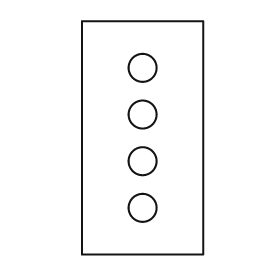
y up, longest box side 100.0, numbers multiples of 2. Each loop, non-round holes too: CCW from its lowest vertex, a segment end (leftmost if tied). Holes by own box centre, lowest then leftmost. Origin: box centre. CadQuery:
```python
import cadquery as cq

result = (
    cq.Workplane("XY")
    .moveTo(-26.0, -50.0)
    .lineTo(26.0, -50.0)
    .lineTo(26.0, 50.0)
    .lineTo(-26.0, 50.0)
    .close()
    .moveTo(0.0, -30.0)
    .circle(6.0)
    .moveTo(0.0, -10.0)
    .circle(6.0)
    .moveTo(0.0, 10.0)
    .circle(6.0)
    .moveTo(0.0, 30.0)
    .circle(6.0)
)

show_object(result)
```